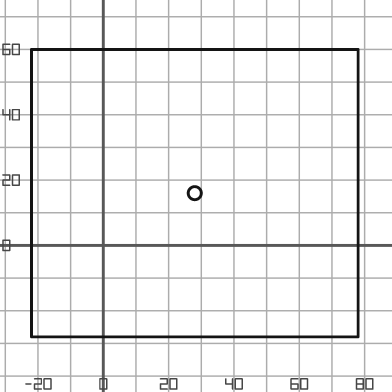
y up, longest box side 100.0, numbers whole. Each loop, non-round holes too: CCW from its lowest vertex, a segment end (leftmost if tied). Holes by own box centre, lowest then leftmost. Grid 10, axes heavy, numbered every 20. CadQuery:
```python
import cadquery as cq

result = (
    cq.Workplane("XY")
    .moveTo(-22.0, -28.0)
    .lineTo(78.0, -28.0)
    .lineTo(78.0, 60.0)
    .lineTo(-22.0, 60.0)
    .close()
    .moveTo(28.0, 16.0)
    .circle(2.0)
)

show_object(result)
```